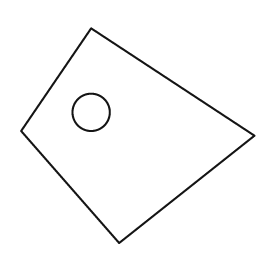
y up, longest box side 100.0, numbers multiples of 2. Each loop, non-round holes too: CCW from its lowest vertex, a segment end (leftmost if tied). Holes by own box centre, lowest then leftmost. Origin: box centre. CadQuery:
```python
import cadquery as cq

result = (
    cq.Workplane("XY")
    .moveTo(-8.0, -46.0)
    .lineTo(50.0, 0.0)
    .lineTo(-20.0, 46.0)
    .lineTo(-50.0, 2.0)
    .close()
    .moveTo(-20.0, 10.0)
    .circle(8.0)
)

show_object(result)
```